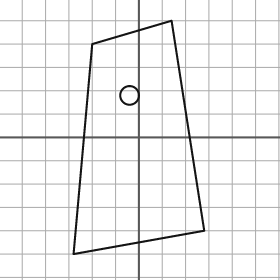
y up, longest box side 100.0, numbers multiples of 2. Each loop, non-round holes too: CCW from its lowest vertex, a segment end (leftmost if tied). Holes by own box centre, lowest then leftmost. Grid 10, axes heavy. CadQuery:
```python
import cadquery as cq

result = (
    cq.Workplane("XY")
    .moveTo(-28.0, -50.0)
    .lineTo(28.0, -40.0)
    .lineTo(14.0, 50.0)
    .lineTo(-20.0, 40.0)
    .close()
    .moveTo(-4.0, 18.0)
    .circle(4.0)
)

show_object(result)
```